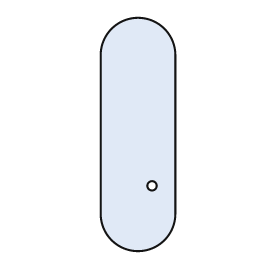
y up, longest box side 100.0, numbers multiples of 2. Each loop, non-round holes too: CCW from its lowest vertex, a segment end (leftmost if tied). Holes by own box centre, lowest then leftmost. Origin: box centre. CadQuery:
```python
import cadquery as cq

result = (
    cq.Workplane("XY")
    .moveTo(-16.0, -34.0)
    .threePointArc((0.0, -50.0), (16.0, -34.0))
    .lineTo(16.0, 34.0)
    .threePointArc((0.0, 50.0), (-16.0, 34.0))
    .close()
    .moveTo(6.0, -22.0)
    .circle(2.0)
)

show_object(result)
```